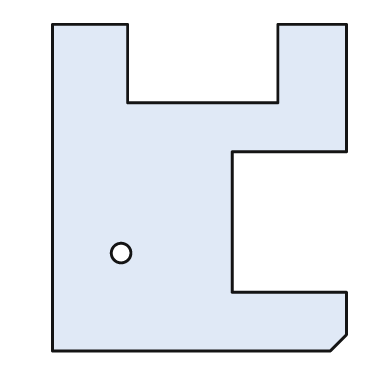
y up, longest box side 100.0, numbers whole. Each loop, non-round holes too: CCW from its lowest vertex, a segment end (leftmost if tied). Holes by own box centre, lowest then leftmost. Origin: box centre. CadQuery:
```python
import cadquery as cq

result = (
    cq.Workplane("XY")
    .moveTo(-45.0, -50.0)
    .lineTo(40.0, -50.0)
    .lineTo(45.0, -45.0)
    .lineTo(45.0, -32.0)
    .lineTo(10.0, -32.0)
    .lineTo(10.0, 11.0)
    .lineTo(45.0, 11.0)
    .lineTo(45.0, 50.0)
    .lineTo(24.0, 50.0)
    .lineTo(24.0, 26.0)
    .lineTo(-22.0, 26.0)
    .lineTo(-22.0, 50.0)
    .lineTo(-45.0, 50.0)
    .close()
    .moveTo(-24.0, -20.0)
    .circle(3.0)
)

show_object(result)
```